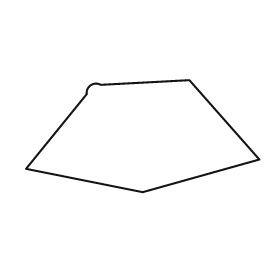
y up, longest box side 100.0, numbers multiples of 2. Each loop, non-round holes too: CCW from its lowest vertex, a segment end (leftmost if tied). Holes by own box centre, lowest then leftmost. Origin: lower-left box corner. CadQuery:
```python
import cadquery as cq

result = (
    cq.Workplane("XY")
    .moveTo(50.0, 0.0)
    .lineTo(100.0, 14.0)
    .lineTo(70.0, 48.0)
    .lineTo(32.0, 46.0)
    .threePointArc((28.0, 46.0), (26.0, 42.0))
    .lineTo(0.0, 10.0)
    .close()
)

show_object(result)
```